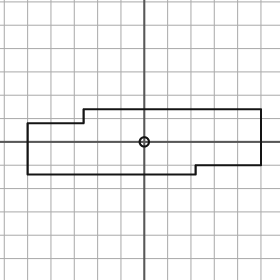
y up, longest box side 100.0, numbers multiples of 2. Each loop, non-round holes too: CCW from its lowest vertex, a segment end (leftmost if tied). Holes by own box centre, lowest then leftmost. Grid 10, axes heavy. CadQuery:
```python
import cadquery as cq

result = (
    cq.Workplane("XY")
    .moveTo(-50.0, -14.0)
    .lineTo(22.0, -14.0)
    .lineTo(22.0, -10.0)
    .lineTo(50.0, -10.0)
    .lineTo(50.0, 14.0)
    .lineTo(-26.0, 14.0)
    .lineTo(-26.0, 8.0)
    .lineTo(-50.0, 8.0)
    .close()
    .moveTo(0.0, 0.0)
    .circle(2.0)
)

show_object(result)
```